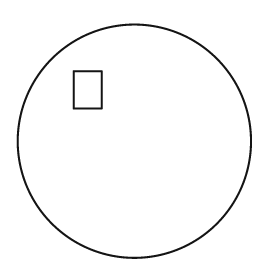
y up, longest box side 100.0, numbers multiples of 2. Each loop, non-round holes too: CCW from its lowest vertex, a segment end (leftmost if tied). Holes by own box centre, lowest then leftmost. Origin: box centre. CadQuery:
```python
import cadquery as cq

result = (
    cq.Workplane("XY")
    .moveTo(0.0, 0.0)
    .circle(50.0)
    .moveTo(-26.0, 14.0)
    .lineTo(-14.0, 14.0)
    .lineTo(-14.0, 30.0)
    .lineTo(-26.0, 30.0)
    .close()
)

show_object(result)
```